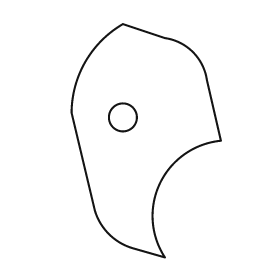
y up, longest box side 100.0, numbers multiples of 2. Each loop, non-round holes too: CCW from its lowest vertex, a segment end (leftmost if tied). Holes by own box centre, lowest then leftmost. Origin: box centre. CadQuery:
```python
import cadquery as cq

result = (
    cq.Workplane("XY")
    .moveTo(8.0, -50.0)
    .threePointArc((6.0, -18.0), (32.0, 0.0))
    .lineTo(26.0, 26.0)
    .threePointArc((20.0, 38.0), (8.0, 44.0))
    .lineTo(-10.0, 50.0)
    .threePointArc((-26.0, 34.0), (-32.0, 12.0))
    .lineTo(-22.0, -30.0)
    .threePointArc((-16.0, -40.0), (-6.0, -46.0))
    .close()
    .moveTo(-10.0, 10.0)
    .circle(6.0)
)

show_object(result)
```